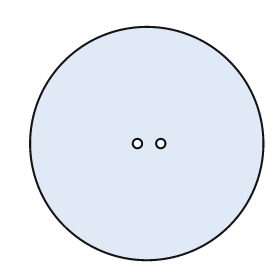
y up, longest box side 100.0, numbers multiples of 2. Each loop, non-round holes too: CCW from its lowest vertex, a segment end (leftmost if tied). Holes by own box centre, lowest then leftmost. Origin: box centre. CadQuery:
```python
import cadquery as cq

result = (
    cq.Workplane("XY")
    .moveTo(0.0, 0.0)
    .circle(50.0)
    .moveTo(-4.0, 0.0)
    .circle(2.0)
    .moveTo(6.0, 0.0)
    .circle(2.0)
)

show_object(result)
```